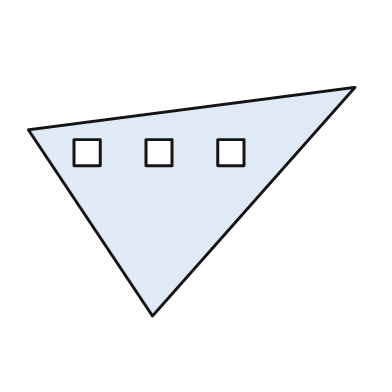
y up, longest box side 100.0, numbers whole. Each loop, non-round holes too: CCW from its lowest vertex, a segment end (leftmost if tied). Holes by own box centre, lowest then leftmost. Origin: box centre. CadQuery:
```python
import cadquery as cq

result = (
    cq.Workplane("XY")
    .moveTo(-12.0, -35.0)
    .lineTo(50.0, 35.0)
    .lineTo(-50.0, 22.0)
    .close()
    .moveTo(-36.0, 11.0)
    .lineTo(-28.0, 11.0)
    .lineTo(-28.0, 19.0)
    .lineTo(-36.0, 19.0)
    .close()
    .moveTo(-14.0, 11.0)
    .lineTo(-6.0, 11.0)
    .lineTo(-6.0, 19.0)
    .lineTo(-14.0, 19.0)
    .close()
    .moveTo(8.0, 11.0)
    .lineTo(16.0, 11.0)
    .lineTo(16.0, 19.0)
    .lineTo(8.0, 19.0)
    .close()
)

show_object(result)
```